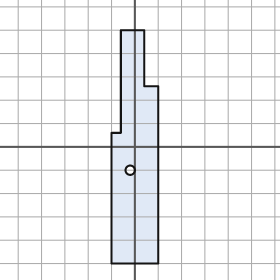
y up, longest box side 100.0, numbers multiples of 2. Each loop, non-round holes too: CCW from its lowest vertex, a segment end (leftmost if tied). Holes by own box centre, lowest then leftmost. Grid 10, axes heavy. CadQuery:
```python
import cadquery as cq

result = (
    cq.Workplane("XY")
    .moveTo(-10.0, -50.0)
    .lineTo(10.0, -50.0)
    .lineTo(10.0, 26.0)
    .lineTo(4.0, 26.0)
    .lineTo(4.0, 50.0)
    .lineTo(-6.0, 50.0)
    .lineTo(-6.0, 6.0)
    .lineTo(-10.0, 6.0)
    .close()
    .moveTo(-2.0, -10.0)
    .circle(2.0)
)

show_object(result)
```